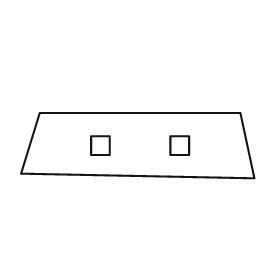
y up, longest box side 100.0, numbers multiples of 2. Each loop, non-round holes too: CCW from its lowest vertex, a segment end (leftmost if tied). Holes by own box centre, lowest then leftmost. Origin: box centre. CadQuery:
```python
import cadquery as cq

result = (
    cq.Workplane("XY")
    .moveTo(50.0, -14.0)
    .lineTo(44.0, 14.0)
    .lineTo(-42.0, 14.0)
    .lineTo(-50.0, -12.0)
    .close()
    .moveTo(-20.0, -4.0)
    .lineTo(-12.0, -4.0)
    .lineTo(-12.0, 4.0)
    .lineTo(-20.0, 4.0)
    .close()
    .moveTo(14.0, -4.0)
    .lineTo(22.0, -4.0)
    .lineTo(22.0, 4.0)
    .lineTo(14.0, 4.0)
    .close()
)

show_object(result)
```